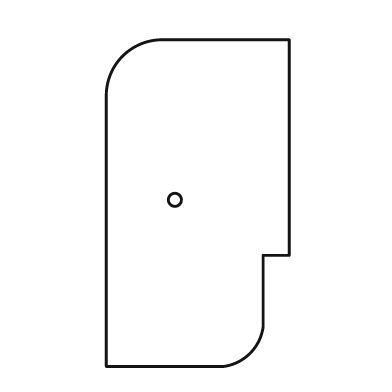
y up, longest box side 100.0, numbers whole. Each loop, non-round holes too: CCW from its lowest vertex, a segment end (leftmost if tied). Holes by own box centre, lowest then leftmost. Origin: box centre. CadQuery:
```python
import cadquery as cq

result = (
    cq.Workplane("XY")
    .moveTo(-28.0, -50.0)
    .lineTo(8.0, -50.0)
    .threePointArc((16.0, -46.0), (20.0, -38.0))
    .lineTo(20.0, -16.0)
    .lineTo(28.0, -16.0)
    .lineTo(28.0, 50.0)
    .lineTo(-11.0, 50.0)
    .threePointArc((-23.0, 45.0), (-28.0, 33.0))
    .close()
    .moveTo(-7.0, 1.0)
    .circle(2.0)
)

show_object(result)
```